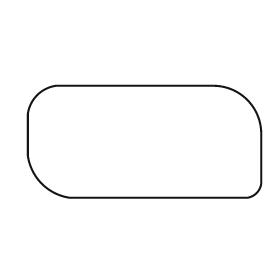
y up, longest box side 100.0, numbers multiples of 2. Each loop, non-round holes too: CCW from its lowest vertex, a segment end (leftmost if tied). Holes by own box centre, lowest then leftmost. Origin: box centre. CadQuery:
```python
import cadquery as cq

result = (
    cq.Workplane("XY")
    .moveTo(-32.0, -24.0)
    .lineTo(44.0, -24.0)
    .threePointArc((48.0, -22.0), (50.0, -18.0))
    .lineTo(50.0, 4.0)
    .threePointArc((44.0, 18.0), (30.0, 24.0))
    .lineTo(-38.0, 24.0)
    .threePointArc((-46.0, 20.0), (-50.0, 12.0))
    .lineTo(-50.0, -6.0)
    .threePointArc((-44.0, -18.0), (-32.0, -24.0))
    .close()
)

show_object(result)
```